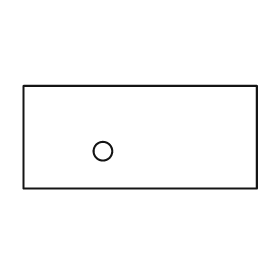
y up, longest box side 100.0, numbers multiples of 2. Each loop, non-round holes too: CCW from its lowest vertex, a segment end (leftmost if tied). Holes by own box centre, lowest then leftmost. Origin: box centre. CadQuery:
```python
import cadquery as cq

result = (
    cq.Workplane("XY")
    .moveTo(-50.0, -22.0)
    .lineTo(50.0, -22.0)
    .lineTo(50.0, 22.0)
    .lineTo(-50.0, 22.0)
    .close()
    .moveTo(-16.0, -6.0)
    .circle(4.0)
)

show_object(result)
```